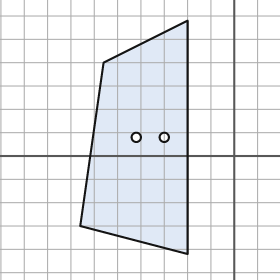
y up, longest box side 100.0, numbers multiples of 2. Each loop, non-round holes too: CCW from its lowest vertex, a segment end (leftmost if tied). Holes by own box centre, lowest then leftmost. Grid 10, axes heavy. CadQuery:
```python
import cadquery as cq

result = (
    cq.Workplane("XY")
    .moveTo(-20.0, -42.0)
    .lineTo(-20.0, 58.0)
    .lineTo(-56.0, 40.0)
    .lineTo(-66.0, -30.0)
    .close()
    .moveTo(-42.0, 8.0)
    .circle(2.0)
    .moveTo(-30.0, 8.0)
    .circle(2.0)
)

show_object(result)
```